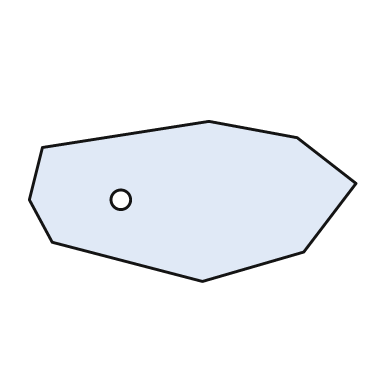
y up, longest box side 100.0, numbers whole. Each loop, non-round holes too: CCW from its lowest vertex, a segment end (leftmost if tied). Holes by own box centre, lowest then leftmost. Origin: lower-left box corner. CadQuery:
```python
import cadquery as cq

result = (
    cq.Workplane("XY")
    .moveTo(53.0, 0.0)
    .lineTo(84.0, 9.0)
    .lineTo(100.0, 30.0)
    .lineTo(82.0, 44.0)
    .lineTo(55.0, 49.0)
    .lineTo(4.0, 41.0)
    .lineTo(0.0, 25.0)
    .lineTo(7.0, 12.0)
    .close()
    .moveTo(28.0, 25.0)
    .circle(3.0)
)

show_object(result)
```